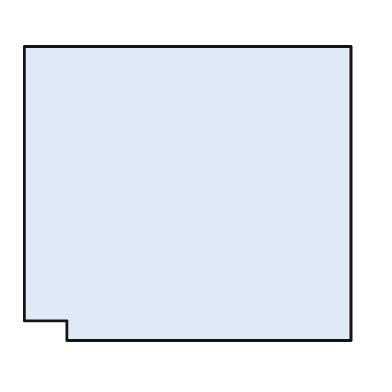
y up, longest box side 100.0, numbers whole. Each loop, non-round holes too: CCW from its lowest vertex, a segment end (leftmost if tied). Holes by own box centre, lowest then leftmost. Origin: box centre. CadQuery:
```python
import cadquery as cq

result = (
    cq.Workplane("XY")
    .moveTo(-37.0, -45.0)
    .lineTo(50.0, -45.0)
    .lineTo(50.0, 45.0)
    .lineTo(-50.0, 45.0)
    .lineTo(-50.0, -39.0)
    .lineTo(-37.0, -39.0)
    .close()
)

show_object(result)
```